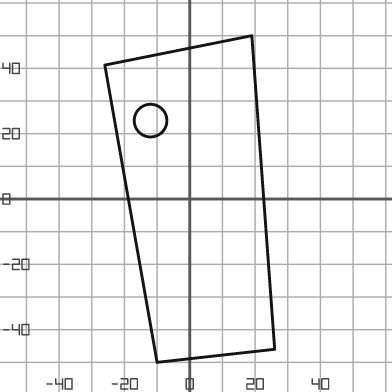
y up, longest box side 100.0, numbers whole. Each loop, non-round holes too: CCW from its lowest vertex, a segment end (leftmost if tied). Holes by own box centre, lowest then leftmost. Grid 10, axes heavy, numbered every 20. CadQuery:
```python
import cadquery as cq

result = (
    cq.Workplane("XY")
    .moveTo(-10.0, -50.0)
    .lineTo(26.0, -46.0)
    .lineTo(19.0, 50.0)
    .lineTo(-26.0, 41.0)
    .close()
    .moveTo(-12.0, 24.0)
    .circle(5.0)
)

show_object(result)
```